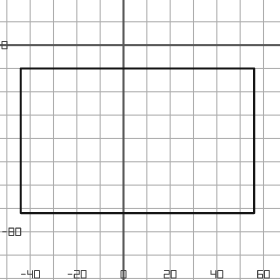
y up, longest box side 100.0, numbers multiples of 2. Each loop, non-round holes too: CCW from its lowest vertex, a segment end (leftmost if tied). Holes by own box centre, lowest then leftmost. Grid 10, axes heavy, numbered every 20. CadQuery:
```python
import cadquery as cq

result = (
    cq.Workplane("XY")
    .moveTo(-44.0, -72.0)
    .lineTo(56.0, -72.0)
    .lineTo(56.0, -10.0)
    .lineTo(-44.0, -10.0)
    .close()
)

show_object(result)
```